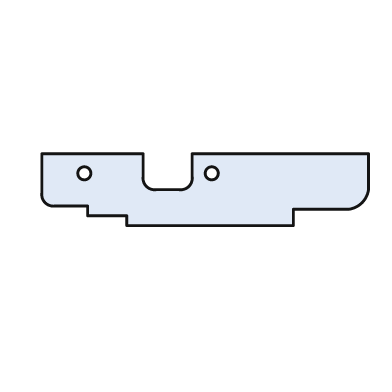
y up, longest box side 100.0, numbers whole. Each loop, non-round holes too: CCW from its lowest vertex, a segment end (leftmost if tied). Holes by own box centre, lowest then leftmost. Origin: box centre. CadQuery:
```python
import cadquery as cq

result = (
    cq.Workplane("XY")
    .moveTo(-24.0, -11.0)
    .lineTo(27.0, -11.0)
    .lineTo(27.0, -6.0)
    .lineTo(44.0, -6.0)
    .threePointArc((48.0, -4.0), (50.0, 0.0))
    .lineTo(50.0, 11.0)
    .lineTo(-4.0, 11.0)
    .lineTo(-4.0, 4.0)
    .threePointArc((-5.0, 1.0), (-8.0, 0.0))
    .lineTo(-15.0, 0.0)
    .threePointArc((-18.0, 1.0), (-19.0, 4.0))
    .lineTo(-19.0, 11.0)
    .lineTo(-50.0, 11.0)
    .lineTo(-50.0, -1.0)
    .threePointArc((-49.0, -4.0), (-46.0, -5.0))
    .lineTo(-36.0, -5.0)
    .lineTo(-36.0, -8.0)
    .lineTo(-24.0, -8.0)
    .close()
    .moveTo(-37.0, 5.0)
    .circle(2.0)
    .moveTo(2.0, 5.0)
    .circle(2.0)
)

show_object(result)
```